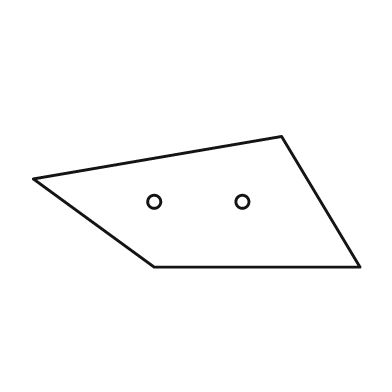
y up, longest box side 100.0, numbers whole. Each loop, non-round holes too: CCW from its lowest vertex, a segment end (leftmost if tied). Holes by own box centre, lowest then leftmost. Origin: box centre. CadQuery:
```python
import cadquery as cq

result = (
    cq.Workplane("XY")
    .moveTo(-13.0, -20.0)
    .lineTo(50.0, -20.0)
    .lineTo(26.0, 20.0)
    .lineTo(-50.0, 7.0)
    .close()
    .moveTo(-13.0, 0.0)
    .circle(2.0)
    .moveTo(14.0, 0.0)
    .circle(2.0)
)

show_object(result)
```